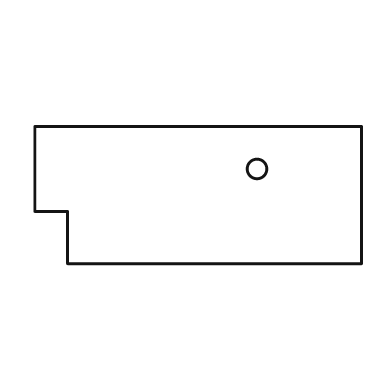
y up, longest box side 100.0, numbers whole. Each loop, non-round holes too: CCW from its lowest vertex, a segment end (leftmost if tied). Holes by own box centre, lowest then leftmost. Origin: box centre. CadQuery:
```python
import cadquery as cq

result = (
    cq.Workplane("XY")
    .moveTo(-40.0, -21.0)
    .lineTo(50.0, -21.0)
    .lineTo(50.0, 21.0)
    .lineTo(-50.0, 21.0)
    .lineTo(-50.0, -5.0)
    .lineTo(-40.0, -5.0)
    .close()
    .moveTo(18.0, 8.0)
    .circle(3.0)
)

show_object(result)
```